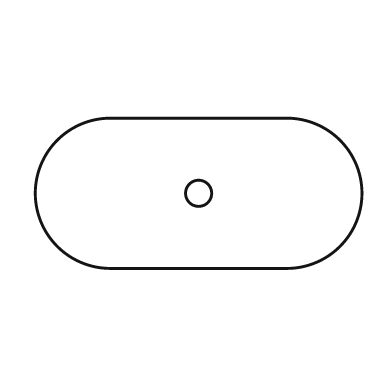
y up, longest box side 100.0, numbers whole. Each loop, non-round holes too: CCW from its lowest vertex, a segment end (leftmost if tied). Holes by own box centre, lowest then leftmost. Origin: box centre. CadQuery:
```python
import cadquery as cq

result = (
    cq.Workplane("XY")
    .moveTo(-27.0, -23.0)
    .lineTo(27.0, -23.0)
    .threePointArc((50.0, 0.0), (27.0, 23.0))
    .lineTo(-27.0, 23.0)
    .threePointArc((-50.0, 0.0), (-27.0, -23.0))
    .close()
    .moveTo(0.0, 0.0)
    .circle(4.0)
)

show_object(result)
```